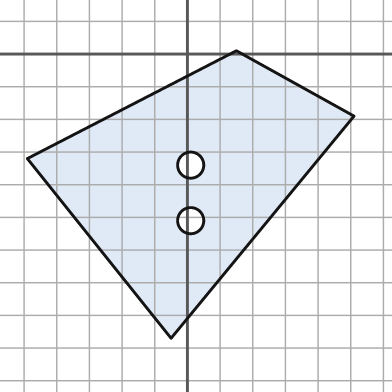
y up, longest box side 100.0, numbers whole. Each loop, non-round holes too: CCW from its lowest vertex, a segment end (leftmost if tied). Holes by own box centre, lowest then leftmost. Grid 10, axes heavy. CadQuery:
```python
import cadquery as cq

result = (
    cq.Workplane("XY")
    .moveTo(-5.0, -87.0)
    .lineTo(51.0, -19.0)
    .lineTo(15.0, 1.0)
    .lineTo(-49.0, -32.0)
    .close()
    .moveTo(1.0, -51.0)
    .circle(4.0)
    .moveTo(1.0, -34.0)
    .circle(4.0)
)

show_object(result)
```